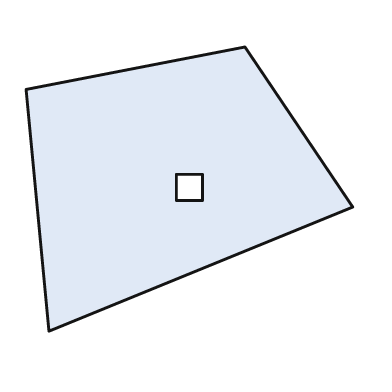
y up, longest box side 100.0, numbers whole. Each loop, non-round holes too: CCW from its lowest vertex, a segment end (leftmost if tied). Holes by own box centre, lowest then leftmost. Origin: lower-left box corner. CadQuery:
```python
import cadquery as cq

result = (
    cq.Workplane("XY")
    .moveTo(7.0, 0.0)
    .lineTo(100.0, 38.0)
    .lineTo(67.0, 87.0)
    .lineTo(0.0, 74.0)
    .close()
    .moveTo(46.0, 40.0)
    .lineTo(54.0, 40.0)
    .lineTo(54.0, 48.0)
    .lineTo(46.0, 48.0)
    .close()
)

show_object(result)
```